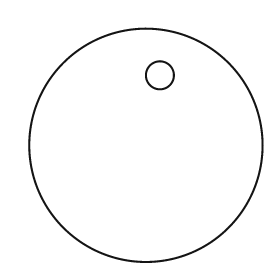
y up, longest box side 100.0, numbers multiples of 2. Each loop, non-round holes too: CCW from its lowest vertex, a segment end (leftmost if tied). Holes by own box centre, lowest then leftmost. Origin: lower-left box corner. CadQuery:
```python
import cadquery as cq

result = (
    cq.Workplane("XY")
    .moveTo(50.0, 50.0)
    .circle(50.0)
    .moveTo(56.0, 80.0)
    .circle(6.0)
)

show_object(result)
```